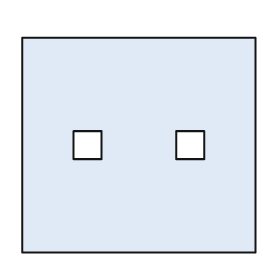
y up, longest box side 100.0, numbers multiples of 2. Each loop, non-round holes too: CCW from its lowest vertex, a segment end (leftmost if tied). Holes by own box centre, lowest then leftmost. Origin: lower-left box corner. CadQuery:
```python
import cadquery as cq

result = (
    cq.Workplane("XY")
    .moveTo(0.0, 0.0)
    .lineTo(100.0, 0.0)
    .lineTo(100.0, 92.0)
    .lineTo(0.0, 92.0)
    .close()
    .moveTo(22.0, 40.0)
    .lineTo(34.0, 40.0)
    .lineTo(34.0, 52.0)
    .lineTo(22.0, 52.0)
    .close()
    .moveTo(66.0, 40.0)
    .lineTo(78.0, 40.0)
    .lineTo(78.0, 52.0)
    .lineTo(66.0, 52.0)
    .close()
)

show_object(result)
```